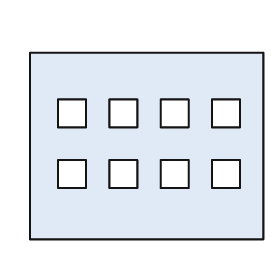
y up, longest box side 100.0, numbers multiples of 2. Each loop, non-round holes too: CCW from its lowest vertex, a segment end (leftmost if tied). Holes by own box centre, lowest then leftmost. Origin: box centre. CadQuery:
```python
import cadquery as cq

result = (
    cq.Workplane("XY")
    .moveTo(-50.0, -40.0)
    .lineTo(50.0, -40.0)
    .lineTo(50.0, 40.0)
    .lineTo(-50.0, 40.0)
    .close()
    .moveTo(-38.0, -18.0)
    .lineTo(-26.0, -18.0)
    .lineTo(-26.0, -6.0)
    .lineTo(-38.0, -6.0)
    .close()
    .moveTo(-16.0, -18.0)
    .lineTo(-4.0, -18.0)
    .lineTo(-4.0, -6.0)
    .lineTo(-16.0, -6.0)
    .close()
    .moveTo(6.0, -18.0)
    .lineTo(18.0, -18.0)
    .lineTo(18.0, -6.0)
    .lineTo(6.0, -6.0)
    .close()
    .moveTo(28.0, -18.0)
    .lineTo(40.0, -18.0)
    .lineTo(40.0, -6.0)
    .lineTo(28.0, -6.0)
    .close()
    .moveTo(-38.0, 8.0)
    .lineTo(-26.0, 8.0)
    .lineTo(-26.0, 20.0)
    .lineTo(-38.0, 20.0)
    .close()
    .moveTo(-16.0, 8.0)
    .lineTo(-4.0, 8.0)
    .lineTo(-4.0, 20.0)
    .lineTo(-16.0, 20.0)
    .close()
    .moveTo(6.0, 8.0)
    .lineTo(18.0, 8.0)
    .lineTo(18.0, 20.0)
    .lineTo(6.0, 20.0)
    .close()
    .moveTo(28.0, 8.0)
    .lineTo(40.0, 8.0)
    .lineTo(40.0, 20.0)
    .lineTo(28.0, 20.0)
    .close()
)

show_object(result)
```